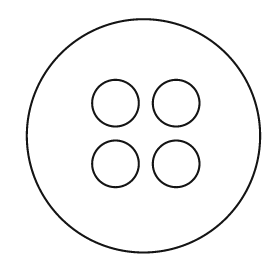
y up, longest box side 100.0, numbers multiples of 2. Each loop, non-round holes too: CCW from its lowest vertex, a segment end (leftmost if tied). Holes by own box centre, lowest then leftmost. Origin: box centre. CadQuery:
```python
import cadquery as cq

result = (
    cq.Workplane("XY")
    .moveTo(0.0, 0.0)
    .circle(50.0)
    .moveTo(-12.0, -12.0)
    .circle(10.0)
    .moveTo(14.0, -12.0)
    .circle(10.0)
    .moveTo(-12.0, 14.0)
    .circle(10.0)
    .moveTo(14.0, 14.0)
    .circle(10.0)
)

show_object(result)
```